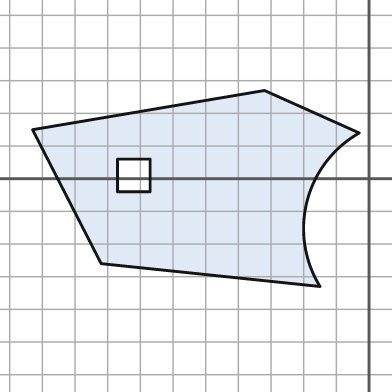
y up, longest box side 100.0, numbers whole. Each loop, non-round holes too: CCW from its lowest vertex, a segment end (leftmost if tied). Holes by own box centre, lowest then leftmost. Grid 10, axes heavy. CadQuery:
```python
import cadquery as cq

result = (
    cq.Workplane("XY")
    .moveTo(-15.0, -33.0)
    .threePointArc((-19.0, -7.0), (-3.0, 14.0))
    .lineTo(-32.0, 27.0)
    .lineTo(-103.0, 15.0)
    .lineTo(-82.0, -26.0)
    .close()
    .moveTo(-77.0, -4.0)
    .lineTo(-67.0, -4.0)
    .lineTo(-67.0, 6.0)
    .lineTo(-77.0, 6.0)
    .close()
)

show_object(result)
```